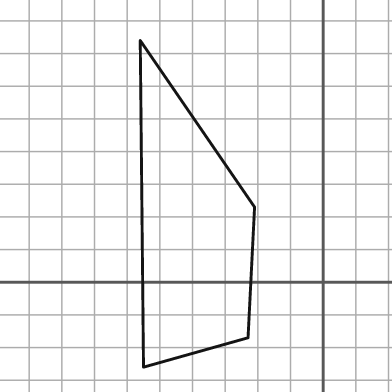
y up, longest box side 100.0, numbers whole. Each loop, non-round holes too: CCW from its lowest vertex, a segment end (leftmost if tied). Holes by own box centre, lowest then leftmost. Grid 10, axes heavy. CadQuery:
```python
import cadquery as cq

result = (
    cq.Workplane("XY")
    .moveTo(-55.0, -26.0)
    .lineTo(-23.0, -17.0)
    .lineTo(-21.0, 23.0)
    .lineTo(-56.0, 74.0)
    .close()
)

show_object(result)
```